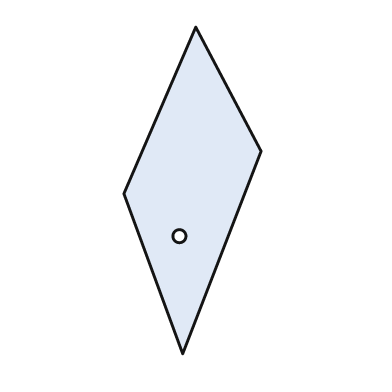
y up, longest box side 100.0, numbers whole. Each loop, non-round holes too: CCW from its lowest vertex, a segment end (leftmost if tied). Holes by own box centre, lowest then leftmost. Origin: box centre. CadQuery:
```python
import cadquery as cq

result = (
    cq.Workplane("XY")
    .moveTo(-3.0, -50.0)
    .lineTo(21.0, 12.0)
    .lineTo(1.0, 50.0)
    .lineTo(-21.0, -1.0)
    .close()
    .moveTo(-4.0, -14.0)
    .circle(2.0)
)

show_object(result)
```